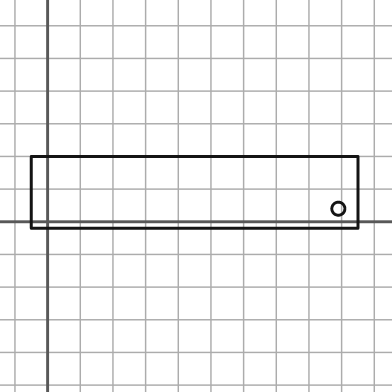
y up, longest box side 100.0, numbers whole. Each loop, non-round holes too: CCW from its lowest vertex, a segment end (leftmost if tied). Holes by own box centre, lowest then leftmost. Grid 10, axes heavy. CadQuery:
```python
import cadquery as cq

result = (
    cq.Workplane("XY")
    .moveTo(-5.0, -2.0)
    .lineTo(95.0, -2.0)
    .lineTo(95.0, 20.0)
    .lineTo(-5.0, 20.0)
    .close()
    .moveTo(89.0, 4.0)
    .circle(2.0)
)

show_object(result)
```